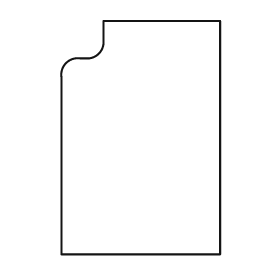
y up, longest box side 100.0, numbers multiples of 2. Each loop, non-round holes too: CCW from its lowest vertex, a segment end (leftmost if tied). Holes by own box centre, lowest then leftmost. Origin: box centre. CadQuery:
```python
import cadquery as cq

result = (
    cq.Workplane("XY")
    .moveTo(-34.0, -50.0)
    .lineTo(34.0, -50.0)
    .lineTo(34.0, 50.0)
    .lineTo(-16.0, 50.0)
    .lineTo(-16.0, 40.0)
    .threePointArc((-18.0, 36.0), (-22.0, 34.0))
    .lineTo(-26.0, 34.0)
    .threePointArc((-32.0, 32.0), (-34.0, 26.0))
    .close()
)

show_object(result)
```